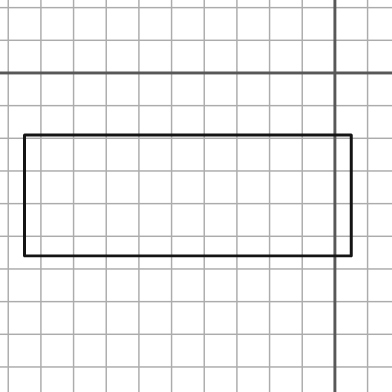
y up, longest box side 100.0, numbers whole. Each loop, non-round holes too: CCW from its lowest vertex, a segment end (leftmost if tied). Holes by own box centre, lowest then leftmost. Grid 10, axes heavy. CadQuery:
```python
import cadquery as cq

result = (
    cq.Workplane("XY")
    .moveTo(-95.0, -56.0)
    .lineTo(5.0, -56.0)
    .lineTo(5.0, -19.0)
    .lineTo(-95.0, -19.0)
    .close()
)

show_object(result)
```